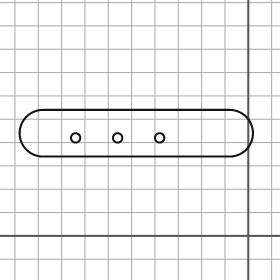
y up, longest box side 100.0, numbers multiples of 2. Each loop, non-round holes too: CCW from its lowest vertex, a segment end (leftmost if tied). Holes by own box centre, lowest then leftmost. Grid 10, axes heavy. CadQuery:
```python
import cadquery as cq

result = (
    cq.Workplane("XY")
    .moveTo(-88.0, 34.0)
    .lineTo(-8.0, 34.0)
    .threePointArc((2.0, 44.0), (-8.0, 54.0))
    .lineTo(-88.0, 54.0)
    .threePointArc((-98.0, 44.0), (-88.0, 34.0))
    .close()
    .moveTo(-74.0, 42.0)
    .circle(2.0)
    .moveTo(-56.0, 42.0)
    .circle(2.0)
    .moveTo(-38.0, 42.0)
    .circle(2.0)
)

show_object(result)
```